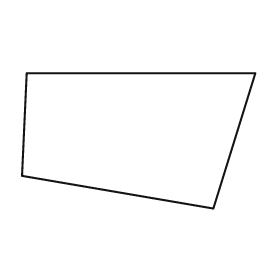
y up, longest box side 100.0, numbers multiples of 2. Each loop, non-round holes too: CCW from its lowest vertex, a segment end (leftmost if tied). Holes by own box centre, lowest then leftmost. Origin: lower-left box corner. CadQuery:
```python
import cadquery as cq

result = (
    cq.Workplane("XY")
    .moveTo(82.0, 0.0)
    .lineTo(100.0, 58.0)
    .lineTo(2.0, 58.0)
    .lineTo(0.0, 14.0)
    .close()
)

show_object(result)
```